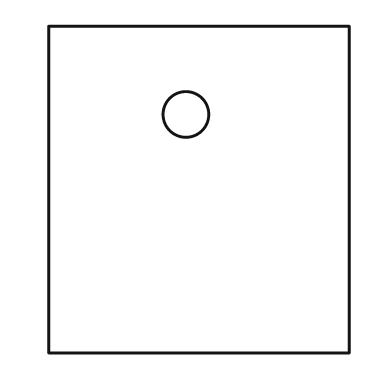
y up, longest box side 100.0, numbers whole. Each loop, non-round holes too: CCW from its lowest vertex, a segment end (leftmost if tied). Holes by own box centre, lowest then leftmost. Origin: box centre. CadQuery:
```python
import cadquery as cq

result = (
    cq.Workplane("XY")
    .moveTo(-46.0, -50.0)
    .lineTo(46.0, -50.0)
    .lineTo(46.0, 50.0)
    .lineTo(-46.0, 50.0)
    .close()
    .moveTo(-4.0, 23.0)
    .circle(7.0)
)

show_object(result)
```